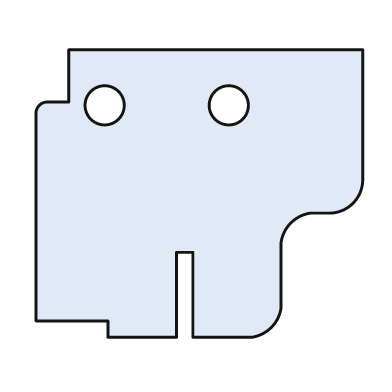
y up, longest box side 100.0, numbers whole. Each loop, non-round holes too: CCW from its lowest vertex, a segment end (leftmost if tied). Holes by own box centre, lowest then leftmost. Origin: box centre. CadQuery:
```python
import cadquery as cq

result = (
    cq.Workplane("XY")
    .moveTo(-28.0, -44.0)
    .lineTo(-7.0, -44.0)
    .lineTo(-7.0, -18.0)
    .lineTo(-2.0, -18.0)
    .lineTo(-2.0, -44.0)
    .lineTo(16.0, -44.0)
    .threePointArc((22.0, -41.0), (25.0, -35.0))
    .lineTo(25.0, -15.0)
    .threePointArc((28.0, -9.0), (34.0, -6.0))
    .lineTo(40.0, -6.0)
    .threePointArc((47.0, -3.0), (50.0, 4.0))
    .lineTo(50.0, 44.0)
    .lineTo(-40.0, 44.0)
    .lineTo(-40.0, 28.0)
    .lineTo(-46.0, 28.0)
    .threePointArc((-49.0, 27.0), (-50.0, 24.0))
    .lineTo(-50.0, -39.0)
    .lineTo(-28.0, -39.0)
    .close()
    .moveTo(-29.0, 27.0)
    .circle(6.0)
    .moveTo(9.0, 27.0)
    .circle(6.0)
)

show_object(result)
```